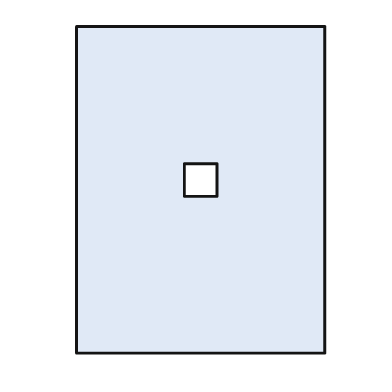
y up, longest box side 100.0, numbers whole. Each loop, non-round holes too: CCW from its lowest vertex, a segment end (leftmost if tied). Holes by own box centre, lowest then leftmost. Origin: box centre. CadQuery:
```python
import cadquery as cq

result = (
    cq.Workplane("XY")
    .moveTo(-38.0, -50.0)
    .lineTo(38.0, -50.0)
    .lineTo(38.0, 50.0)
    .lineTo(-38.0, 50.0)
    .close()
    .moveTo(-5.0, -2.0)
    .lineTo(5.0, -2.0)
    .lineTo(5.0, 8.0)
    .lineTo(-5.0, 8.0)
    .close()
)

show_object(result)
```